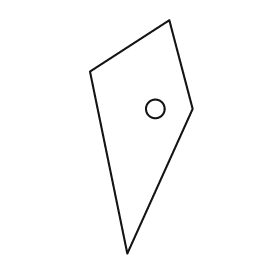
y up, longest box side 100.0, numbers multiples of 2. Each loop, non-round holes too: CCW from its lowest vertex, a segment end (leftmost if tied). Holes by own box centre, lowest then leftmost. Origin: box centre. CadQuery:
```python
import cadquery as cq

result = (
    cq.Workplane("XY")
    .moveTo(-6.0, -50.0)
    .lineTo(22.0, 12.0)
    .lineTo(12.0, 50.0)
    .lineTo(-22.0, 28.0)
    .close()
    .moveTo(6.0, 12.0)
    .circle(4.0)
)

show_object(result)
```